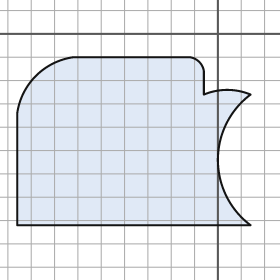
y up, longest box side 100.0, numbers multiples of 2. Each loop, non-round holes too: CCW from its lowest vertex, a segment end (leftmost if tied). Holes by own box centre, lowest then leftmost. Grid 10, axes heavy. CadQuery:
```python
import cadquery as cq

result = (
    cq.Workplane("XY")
    .moveTo(-86.0, -82.0)
    .lineTo(14.0, -82.0)
    .threePointArc((0.0, -54.0), (14.0, -26.0))
    .threePointArc((4.0, -24.0), (-6.0, -26.0))
    .lineTo(-6.0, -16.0)
    .threePointArc((-8.0, -12.0), (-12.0, -10.0))
    .lineTo(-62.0, -10.0)
    .threePointArc((-78.0, -18.0), (-86.0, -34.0))
    .close()
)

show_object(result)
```